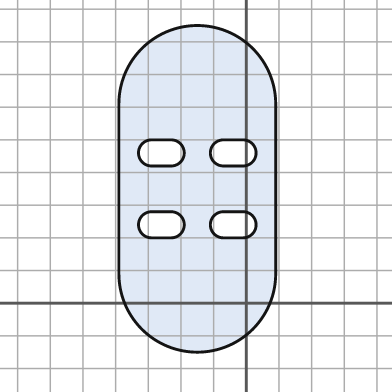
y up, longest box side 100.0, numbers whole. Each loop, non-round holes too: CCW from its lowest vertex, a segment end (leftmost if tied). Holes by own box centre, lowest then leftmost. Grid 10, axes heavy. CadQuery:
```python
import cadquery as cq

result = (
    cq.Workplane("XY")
    .moveTo(-39.0, 9.0)
    .threePointArc((-15.0, -15.0), (9.0, 9.0))
    .lineTo(9.0, 61.0)
    .threePointArc((-15.0, 85.0), (-39.0, 61.0))
    .close()
    .moveTo(-29.0, 20.0)
    .lineTo(-23.0, 20.0)
    .threePointArc((-19.0, 24.0), (-23.0, 28.0))
    .lineTo(-29.0, 28.0)
    .threePointArc((-33.0, 24.0), (-29.0, 20.0))
    .close()
    .moveTo(-7.0, 20.0)
    .lineTo(-1.0, 20.0)
    .threePointArc((3.0, 24.0), (-1.0, 28.0))
    .lineTo(-7.0, 28.0)
    .threePointArc((-11.0, 24.0), (-7.0, 20.0))
    .close()
    .moveTo(-29.0, 42.0)
    .lineTo(-23.0, 42.0)
    .threePointArc((-19.0, 46.0), (-23.0, 50.0))
    .lineTo(-29.0, 50.0)
    .threePointArc((-33.0, 46.0), (-29.0, 42.0))
    .close()
    .moveTo(-7.0, 42.0)
    .lineTo(-1.0, 42.0)
    .threePointArc((3.0, 46.0), (-1.0, 50.0))
    .lineTo(-7.0, 50.0)
    .threePointArc((-11.0, 46.0), (-7.0, 42.0))
    .close()
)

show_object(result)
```